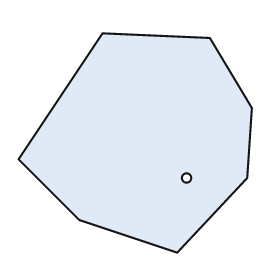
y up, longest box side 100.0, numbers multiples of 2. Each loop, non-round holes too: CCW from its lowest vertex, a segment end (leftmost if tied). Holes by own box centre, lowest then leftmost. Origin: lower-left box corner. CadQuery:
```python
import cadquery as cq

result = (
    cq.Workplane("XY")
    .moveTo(68.0, 0.0)
    .lineTo(98.0, 32.0)
    .lineTo(100.0, 62.0)
    .lineTo(82.0, 92.0)
    .lineTo(36.0, 94.0)
    .lineTo(0.0, 40.0)
    .lineTo(26.0, 14.0)
    .close()
    .moveTo(72.0, 32.0)
    .circle(2.0)
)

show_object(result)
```